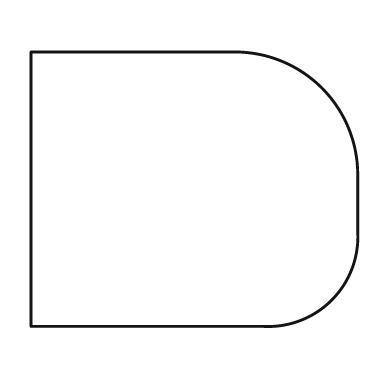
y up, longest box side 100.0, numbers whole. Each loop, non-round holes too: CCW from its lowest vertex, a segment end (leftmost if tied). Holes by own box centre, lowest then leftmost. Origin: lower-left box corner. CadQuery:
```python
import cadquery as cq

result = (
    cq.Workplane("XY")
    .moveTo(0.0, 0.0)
    .lineTo(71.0, 0.0)
    .threePointArc((92.0, 8.0), (100.0, 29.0))
    .lineTo(100.0, 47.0)
    .threePointArc((89.0, 73.0), (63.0, 84.0))
    .lineTo(0.0, 84.0)
    .close()
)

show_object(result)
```